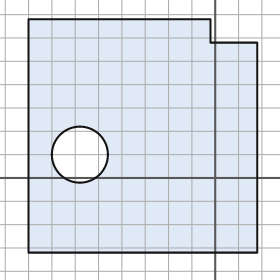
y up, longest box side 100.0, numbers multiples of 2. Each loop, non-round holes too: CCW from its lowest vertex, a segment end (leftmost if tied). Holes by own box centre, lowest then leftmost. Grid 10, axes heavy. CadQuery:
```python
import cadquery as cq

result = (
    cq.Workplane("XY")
    .moveTo(-80.0, -32.0)
    .lineTo(18.0, -32.0)
    .lineTo(18.0, 58.0)
    .lineTo(-2.0, 58.0)
    .lineTo(-2.0, 68.0)
    .lineTo(-80.0, 68.0)
    .close()
    .moveTo(-58.0, 10.0)
    .circle(12.0)
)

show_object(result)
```